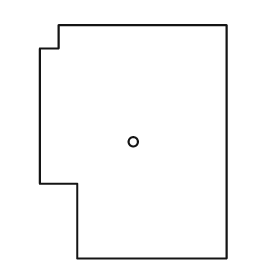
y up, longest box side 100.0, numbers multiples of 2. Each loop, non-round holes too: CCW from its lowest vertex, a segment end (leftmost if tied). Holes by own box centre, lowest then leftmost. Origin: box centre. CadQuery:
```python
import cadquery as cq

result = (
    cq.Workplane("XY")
    .moveTo(-24.0, -50.0)
    .lineTo(40.0, -50.0)
    .lineTo(40.0, 50.0)
    .lineTo(-32.0, 50.0)
    .lineTo(-32.0, 40.0)
    .lineTo(-40.0, 40.0)
    .lineTo(-40.0, -18.0)
    .lineTo(-24.0, -18.0)
    .close()
    .moveTo(0.0, 0.0)
    .circle(2.0)
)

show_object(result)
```